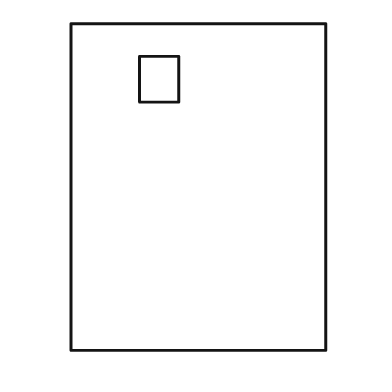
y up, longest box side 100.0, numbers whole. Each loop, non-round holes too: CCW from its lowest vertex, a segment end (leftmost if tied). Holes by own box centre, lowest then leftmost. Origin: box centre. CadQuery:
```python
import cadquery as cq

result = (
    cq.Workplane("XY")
    .moveTo(-39.0, -50.0)
    .lineTo(39.0, -50.0)
    .lineTo(39.0, 50.0)
    .lineTo(-39.0, 50.0)
    .close()
    .moveTo(-18.0, 26.0)
    .lineTo(-6.0, 26.0)
    .lineTo(-6.0, 40.0)
    .lineTo(-18.0, 40.0)
    .close()
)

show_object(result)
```